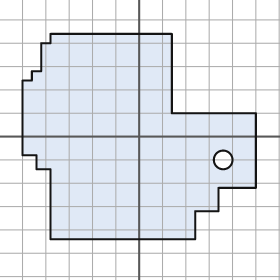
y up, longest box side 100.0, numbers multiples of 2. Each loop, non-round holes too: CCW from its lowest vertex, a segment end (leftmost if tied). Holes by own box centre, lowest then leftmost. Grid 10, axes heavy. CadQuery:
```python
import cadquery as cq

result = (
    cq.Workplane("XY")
    .moveTo(-38.0, -44.0)
    .lineTo(24.0, -44.0)
    .lineTo(24.0, -32.0)
    .lineTo(34.0, -32.0)
    .lineTo(34.0, -22.0)
    .lineTo(50.0, -22.0)
    .lineTo(50.0, 10.0)
    .lineTo(14.0, 10.0)
    .lineTo(14.0, 44.0)
    .lineTo(-38.0, 44.0)
    .lineTo(-38.0, 40.0)
    .lineTo(-42.0, 40.0)
    .lineTo(-42.0, 28.0)
    .lineTo(-46.0, 28.0)
    .lineTo(-46.0, 24.0)
    .lineTo(-50.0, 24.0)
    .lineTo(-50.0, -8.0)
    .lineTo(-44.0, -8.0)
    .lineTo(-44.0, -14.0)
    .lineTo(-38.0, -14.0)
    .close()
    .moveTo(36.0, -10.0)
    .circle(4.0)
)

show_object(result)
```